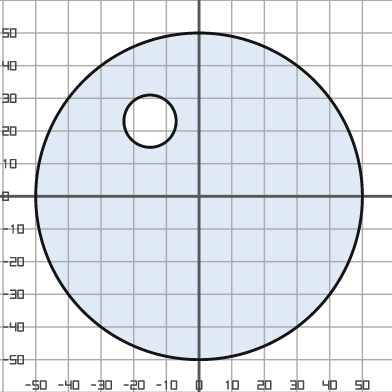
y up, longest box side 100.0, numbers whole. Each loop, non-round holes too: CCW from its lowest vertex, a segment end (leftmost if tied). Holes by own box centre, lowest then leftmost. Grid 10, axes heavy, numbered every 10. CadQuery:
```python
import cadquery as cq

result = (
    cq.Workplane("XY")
    .moveTo(0.0, 0.0)
    .circle(50.0)
    .moveTo(-15.0, 23.0)
    .circle(8.0)
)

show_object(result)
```